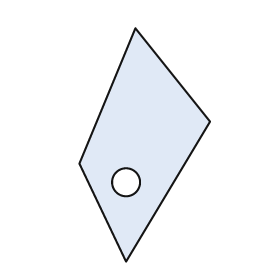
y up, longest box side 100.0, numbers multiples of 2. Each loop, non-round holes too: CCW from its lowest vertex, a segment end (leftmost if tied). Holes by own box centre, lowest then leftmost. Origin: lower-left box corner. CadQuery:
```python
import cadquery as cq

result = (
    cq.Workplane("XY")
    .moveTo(20.0, 0.0)
    .lineTo(56.0, 60.0)
    .lineTo(24.0, 100.0)
    .lineTo(0.0, 42.0)
    .close()
    .moveTo(20.0, 34.0)
    .circle(6.0)
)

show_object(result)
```